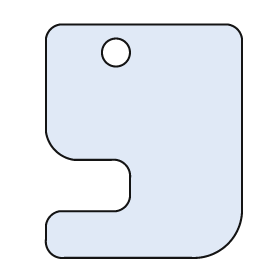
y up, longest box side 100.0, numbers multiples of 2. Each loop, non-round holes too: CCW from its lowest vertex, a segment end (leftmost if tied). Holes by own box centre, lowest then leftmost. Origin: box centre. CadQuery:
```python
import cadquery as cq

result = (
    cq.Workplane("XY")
    .moveTo(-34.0, -50.0)
    .lineTo(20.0, -50.0)
    .threePointArc((36.0, -44.0), (42.0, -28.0))
    .lineTo(42.0, 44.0)
    .threePointArc((40.0, 48.0), (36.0, 50.0))
    .lineTo(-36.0, 50.0)
    .threePointArc((-40.0, 48.0), (-42.0, 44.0))
    .lineTo(-42.0, 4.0)
    .threePointArc((-38.0, -4.0), (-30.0, -8.0))
    .lineTo(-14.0, -8.0)
    .threePointArc((-8.0, -10.0), (-6.0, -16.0))
    .lineTo(-6.0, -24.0)
    .threePointArc((-8.0, -28.0), (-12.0, -30.0))
    .lineTo(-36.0, -30.0)
    .threePointArc((-40.0, -32.0), (-42.0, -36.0))
    .lineTo(-42.0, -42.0)
    .threePointArc((-40.0, -48.0), (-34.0, -50.0))
    .close()
    .moveTo(-12.0, 38.0)
    .circle(6.0)
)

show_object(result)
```